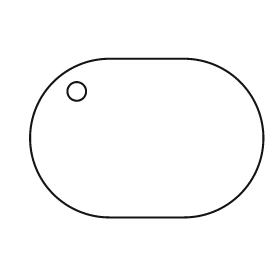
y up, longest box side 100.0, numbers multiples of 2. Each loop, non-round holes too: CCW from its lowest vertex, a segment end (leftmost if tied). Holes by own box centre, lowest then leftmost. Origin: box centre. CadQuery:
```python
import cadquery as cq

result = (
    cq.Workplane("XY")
    .moveTo(-16.0, -34.0)
    .lineTo(16.0, -34.0)
    .threePointArc((50.0, 0.0), (16.0, 34.0))
    .lineTo(-16.0, 34.0)
    .threePointArc((-50.0, 0.0), (-16.0, -34.0))
    .close()
    .moveTo(-30.0, 20.0)
    .circle(4.0)
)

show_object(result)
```